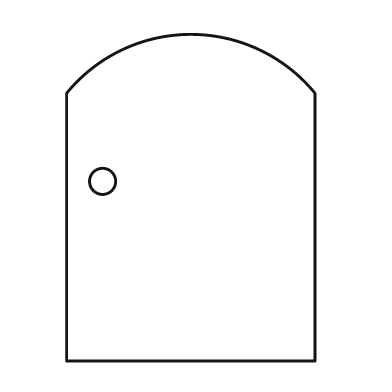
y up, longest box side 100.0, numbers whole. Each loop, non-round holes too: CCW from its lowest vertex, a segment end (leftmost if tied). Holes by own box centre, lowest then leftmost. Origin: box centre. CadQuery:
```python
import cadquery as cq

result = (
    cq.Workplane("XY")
    .moveTo(-38.0, -50.0)
    .lineTo(38.0, -50.0)
    .lineTo(38.0, 32.0)
    .threePointArc((0.0, 50.0), (-38.0, 32.0))
    .close()
    .moveTo(-27.0, 5.0)
    .circle(4.0)
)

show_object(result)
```